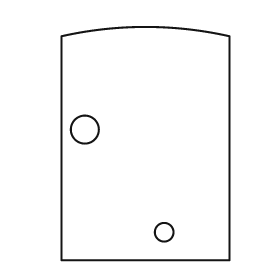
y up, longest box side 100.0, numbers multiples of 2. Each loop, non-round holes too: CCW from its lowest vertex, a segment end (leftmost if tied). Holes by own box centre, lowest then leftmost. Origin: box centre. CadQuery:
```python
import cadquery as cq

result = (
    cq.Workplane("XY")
    .moveTo(-36.0, -50.0)
    .lineTo(36.0, -50.0)
    .lineTo(36.0, 46.0)
    .threePointArc((0.0, 50.0), (-36.0, 46.0))
    .close()
    .moveTo(8.0, -38.0)
    .circle(4.0)
    .moveTo(-26.0, 6.0)
    .circle(6.0)
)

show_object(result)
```